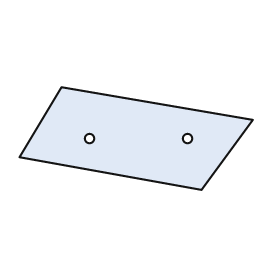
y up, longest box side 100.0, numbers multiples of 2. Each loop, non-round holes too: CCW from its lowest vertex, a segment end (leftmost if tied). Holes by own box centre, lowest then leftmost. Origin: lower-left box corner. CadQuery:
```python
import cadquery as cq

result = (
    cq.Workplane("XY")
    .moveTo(78.0, 0.0)
    .lineTo(100.0, 30.0)
    .lineTo(18.0, 44.0)
    .lineTo(0.0, 14.0)
    .close()
    .moveTo(30.0, 22.0)
    .circle(2.0)
    .moveTo(72.0, 22.0)
    .circle(2.0)
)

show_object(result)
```